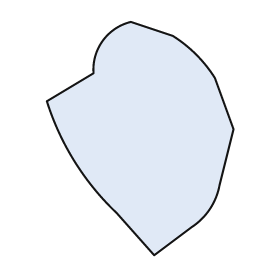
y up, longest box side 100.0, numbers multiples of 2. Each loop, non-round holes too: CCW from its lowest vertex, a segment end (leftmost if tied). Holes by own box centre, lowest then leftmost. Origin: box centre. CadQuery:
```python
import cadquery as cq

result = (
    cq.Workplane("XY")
    .moveTo(6.0, -50.0)
    .lineTo(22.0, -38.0)
    .threePointArc((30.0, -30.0), (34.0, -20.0))
    .lineTo(40.0, 4.0)
    .lineTo(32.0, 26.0)
    .threePointArc((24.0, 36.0), (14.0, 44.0))
    .lineTo(-4.0, 50.0)
    .threePointArc((-16.0, 42.0), (-20.0, 28.0))
    .lineTo(-40.0, 16.0)
    .threePointArc((-28.0, -10.0), (-10.0, -32.0))
    .close()
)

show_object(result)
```